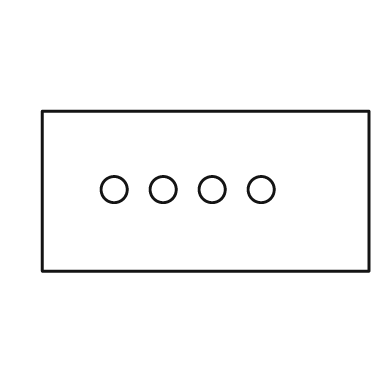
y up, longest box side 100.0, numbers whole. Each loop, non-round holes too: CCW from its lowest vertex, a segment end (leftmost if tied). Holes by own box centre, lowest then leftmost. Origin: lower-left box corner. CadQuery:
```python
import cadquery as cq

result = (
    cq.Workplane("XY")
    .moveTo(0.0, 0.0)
    .lineTo(100.0, 0.0)
    .lineTo(100.0, 49.0)
    .lineTo(0.0, 49.0)
    .close()
    .moveTo(22.0, 25.0)
    .circle(4.0)
    .moveTo(37.0, 25.0)
    .circle(4.0)
    .moveTo(52.0, 25.0)
    .circle(4.0)
    .moveTo(67.0, 25.0)
    .circle(4.0)
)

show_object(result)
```